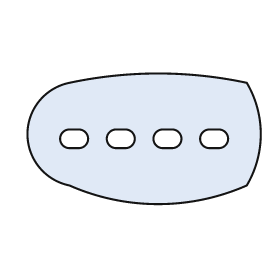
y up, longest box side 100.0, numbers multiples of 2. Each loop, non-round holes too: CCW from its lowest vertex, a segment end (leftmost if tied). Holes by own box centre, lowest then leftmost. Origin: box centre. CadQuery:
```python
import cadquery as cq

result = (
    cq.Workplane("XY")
    .moveTo(-32.0, -20.0)
    .threePointArc((6.0, -28.0), (44.0, -20.0))
    .threePointArc((50.0, 2.0), (44.0, 24.0))
    .threePointArc((6.0, 28.0), (-32.0, 24.0))
    .threePointArc((-50.0, 2.0), (-32.0, -20.0))
    .close()
    .moveTo(-32.0, -4.0)
    .lineTo(-28.0, -4.0)
    .threePointArc((-24.0, 0.0), (-28.0, 4.0))
    .lineTo(-32.0, 4.0)
    .threePointArc((-36.0, 0.0), (-32.0, -4.0))
    .close()
    .moveTo(-12.0, -4.0)
    .lineTo(-8.0, -4.0)
    .threePointArc((-4.0, 0.0), (-8.0, 4.0))
    .lineTo(-12.0, 4.0)
    .threePointArc((-16.0, 0.0), (-12.0, -4.0))
    .close()
    .moveTo(8.0, -4.0)
    .lineTo(12.0, -4.0)
    .threePointArc((16.0, 0.0), (12.0, 4.0))
    .lineTo(8.0, 4.0)
    .threePointArc((4.0, 0.0), (8.0, -4.0))
    .close()
    .moveTo(28.0, -4.0)
    .lineTo(32.0, -4.0)
    .threePointArc((36.0, 0.0), (32.0, 4.0))
    .lineTo(28.0, 4.0)
    .threePointArc((24.0, 0.0), (28.0, -4.0))
    .close()
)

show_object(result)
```